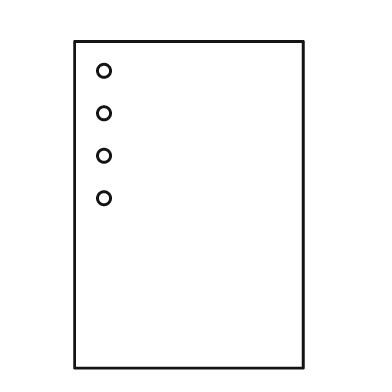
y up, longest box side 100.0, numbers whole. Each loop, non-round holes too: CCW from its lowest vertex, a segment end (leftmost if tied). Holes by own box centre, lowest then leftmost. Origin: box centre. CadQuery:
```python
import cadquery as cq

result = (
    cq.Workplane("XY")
    .moveTo(-35.0, -50.0)
    .lineTo(35.0, -50.0)
    .lineTo(35.0, 50.0)
    .lineTo(-35.0, 50.0)
    .close()
    .moveTo(-26.0, 2.0)
    .circle(2.0)
    .moveTo(-26.0, 15.0)
    .circle(2.0)
    .moveTo(-26.0, 28.0)
    .circle(2.0)
    .moveTo(-26.0, 41.0)
    .circle(2.0)
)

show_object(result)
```